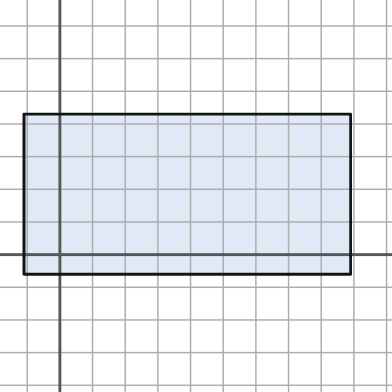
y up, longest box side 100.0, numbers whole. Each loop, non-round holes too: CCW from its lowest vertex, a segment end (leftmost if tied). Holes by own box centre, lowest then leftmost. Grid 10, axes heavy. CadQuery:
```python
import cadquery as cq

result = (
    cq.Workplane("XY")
    .moveTo(-11.0, -6.0)
    .lineTo(89.0, -6.0)
    .lineTo(89.0, 43.0)
    .lineTo(-11.0, 43.0)
    .close()
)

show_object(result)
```